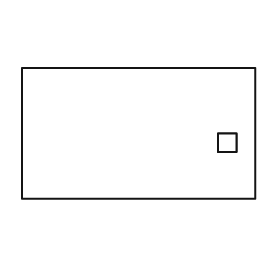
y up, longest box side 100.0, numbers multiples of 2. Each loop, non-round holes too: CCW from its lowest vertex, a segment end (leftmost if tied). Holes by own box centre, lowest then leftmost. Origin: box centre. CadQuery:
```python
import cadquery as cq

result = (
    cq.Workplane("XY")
    .moveTo(-50.0, -28.0)
    .lineTo(50.0, -28.0)
    .lineTo(50.0, 28.0)
    .lineTo(-50.0, 28.0)
    .close()
    .moveTo(34.0, -8.0)
    .lineTo(42.0, -8.0)
    .lineTo(42.0, 0.0)
    .lineTo(34.0, 0.0)
    .close()
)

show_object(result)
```